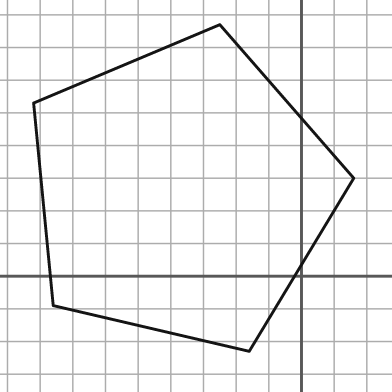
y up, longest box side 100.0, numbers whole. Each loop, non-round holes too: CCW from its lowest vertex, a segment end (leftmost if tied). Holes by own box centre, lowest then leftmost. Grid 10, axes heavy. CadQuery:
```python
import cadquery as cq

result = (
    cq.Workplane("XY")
    .moveTo(-16.0, -23.0)
    .lineTo(16.0, 30.0)
    .lineTo(-25.0, 77.0)
    .lineTo(-82.0, 53.0)
    .lineTo(-76.0, -9.0)
    .close()
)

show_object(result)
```